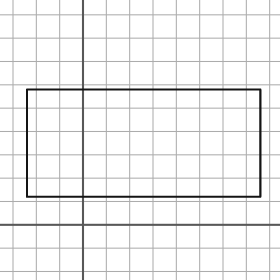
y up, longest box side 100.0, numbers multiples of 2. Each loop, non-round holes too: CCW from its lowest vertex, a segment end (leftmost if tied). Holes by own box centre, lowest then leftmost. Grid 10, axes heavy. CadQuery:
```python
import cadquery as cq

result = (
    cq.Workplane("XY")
    .moveTo(-24.0, 12.0)
    .lineTo(76.0, 12.0)
    .lineTo(76.0, 58.0)
    .lineTo(-24.0, 58.0)
    .close()
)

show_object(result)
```